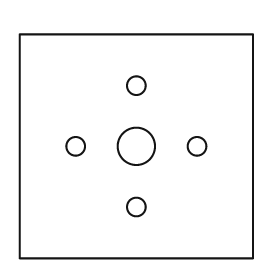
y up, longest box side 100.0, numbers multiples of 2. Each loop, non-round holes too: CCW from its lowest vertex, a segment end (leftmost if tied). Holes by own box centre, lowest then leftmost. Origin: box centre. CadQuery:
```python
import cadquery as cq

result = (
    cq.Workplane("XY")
    .moveTo(-50.0, -48.0)
    .lineTo(50.0, -48.0)
    .lineTo(50.0, 48.0)
    .lineTo(-50.0, 48.0)
    .close()
    .moveTo(0.0, -26.0)
    .circle(4.0)
    .moveTo(-26.0, 0.0)
    .circle(4.0)
    .moveTo(0.0, 0.0)
    .circle(8.0)
    .moveTo(26.0, 0.0)
    .circle(4.0)
    .moveTo(0.0, 26.0)
    .circle(4.0)
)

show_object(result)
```